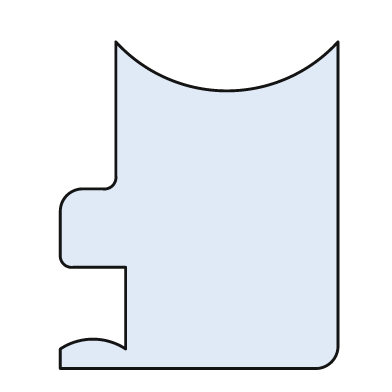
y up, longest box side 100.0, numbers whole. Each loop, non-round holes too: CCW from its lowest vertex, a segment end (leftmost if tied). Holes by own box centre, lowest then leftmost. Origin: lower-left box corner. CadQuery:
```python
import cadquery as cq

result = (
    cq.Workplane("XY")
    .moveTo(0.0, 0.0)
    .lineTo(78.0, 0.0)
    .threePointArc((83.0, 2.0), (85.0, 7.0))
    .lineTo(85.0, 100.0)
    .threePointArc((51.0, 85.0), (17.0, 100.0))
    .lineTo(17.0, 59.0)
    .threePointArc((16.0, 56.0), (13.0, 55.0))
    .lineTo(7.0, 55.0)
    .threePointArc((2.0, 53.0), (0.0, 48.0))
    .lineTo(0.0, 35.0)
    .threePointArc((1.0, 32.0), (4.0, 31.0))
    .lineTo(20.0, 31.0)
    .lineTo(20.0, 6.0)
    .threePointArc((10.0, 9.0), (0.0, 6.0))
    .close()
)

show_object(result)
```